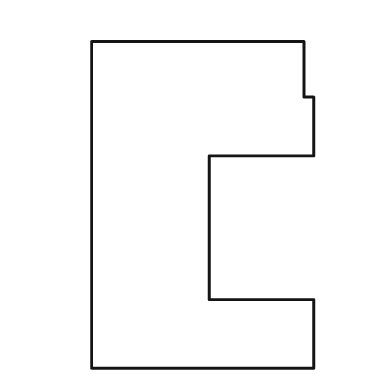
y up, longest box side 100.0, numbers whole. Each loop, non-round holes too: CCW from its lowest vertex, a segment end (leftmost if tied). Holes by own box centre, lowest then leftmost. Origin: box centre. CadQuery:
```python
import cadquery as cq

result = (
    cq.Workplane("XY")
    .moveTo(-34.0, -50.0)
    .lineTo(34.0, -50.0)
    .lineTo(34.0, -29.0)
    .lineTo(2.0, -29.0)
    .lineTo(2.0, 15.0)
    .lineTo(34.0, 15.0)
    .lineTo(34.0, 33.0)
    .lineTo(31.0, 33.0)
    .lineTo(31.0, 50.0)
    .lineTo(-34.0, 50.0)
    .close()
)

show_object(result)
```